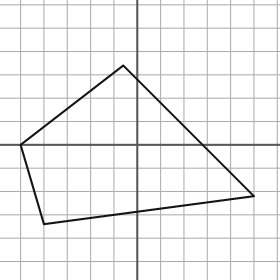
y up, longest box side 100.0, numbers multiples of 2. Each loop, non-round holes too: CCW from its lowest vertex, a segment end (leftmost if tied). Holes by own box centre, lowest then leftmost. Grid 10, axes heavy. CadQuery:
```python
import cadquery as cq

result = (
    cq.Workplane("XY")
    .moveTo(-40.0, -34.0)
    .lineTo(50.0, -22.0)
    .lineTo(-6.0, 34.0)
    .lineTo(-50.0, 0.0)
    .close()
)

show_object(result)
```